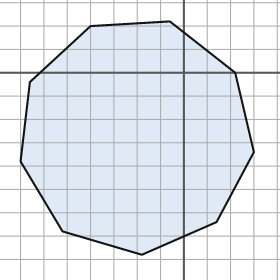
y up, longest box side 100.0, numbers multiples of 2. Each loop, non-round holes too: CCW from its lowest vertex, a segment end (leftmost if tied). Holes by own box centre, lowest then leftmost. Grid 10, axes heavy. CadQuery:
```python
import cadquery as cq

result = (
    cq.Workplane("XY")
    .moveTo(-18.0, -78.0)
    .lineTo(14.0, -64.0)
    .lineTo(30.0, -34.0)
    .lineTo(22.0, 0.0)
    .lineTo(-6.0, 22.0)
    .lineTo(-40.0, 20.0)
    .lineTo(-66.0, -4.0)
    .lineTo(-70.0, -38.0)
    .lineTo(-52.0, -68.0)
    .close()
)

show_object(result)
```